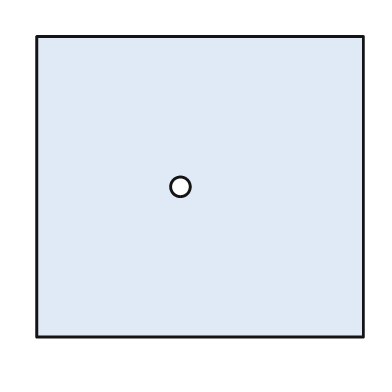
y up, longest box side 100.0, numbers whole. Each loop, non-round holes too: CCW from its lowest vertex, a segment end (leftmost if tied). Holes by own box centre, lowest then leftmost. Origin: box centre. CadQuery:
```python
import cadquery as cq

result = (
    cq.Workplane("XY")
    .moveTo(-50.0, -46.0)
    .lineTo(50.0, -46.0)
    .lineTo(50.0, 46.0)
    .lineTo(-50.0, 46.0)
    .close()
    .moveTo(-6.0, 0.0)
    .circle(3.0)
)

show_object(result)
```